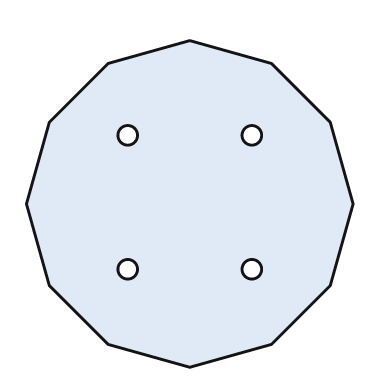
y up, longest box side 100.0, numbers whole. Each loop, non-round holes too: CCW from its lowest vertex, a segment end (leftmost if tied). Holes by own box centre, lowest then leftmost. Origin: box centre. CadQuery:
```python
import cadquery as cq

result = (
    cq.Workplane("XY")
    .moveTo(0.0, -50.0)
    .lineTo(25.0, -43.0)
    .lineTo(43.0, -25.0)
    .lineTo(50.0, 0.0)
    .lineTo(43.0, 25.0)
    .lineTo(25.0, 43.0)
    .lineTo(0.0, 50.0)
    .lineTo(-25.0, 43.0)
    .lineTo(-43.0, 25.0)
    .lineTo(-50.0, 0.0)
    .lineTo(-43.0, -25.0)
    .lineTo(-25.0, -43.0)
    .close()
    .moveTo(-19.0, -20.0)
    .circle(3.0)
    .moveTo(19.0, -20.0)
    .circle(3.0)
    .moveTo(-19.0, 21.0)
    .circle(3.0)
    .moveTo(19.0, 21.0)
    .circle(3.0)
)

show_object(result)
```